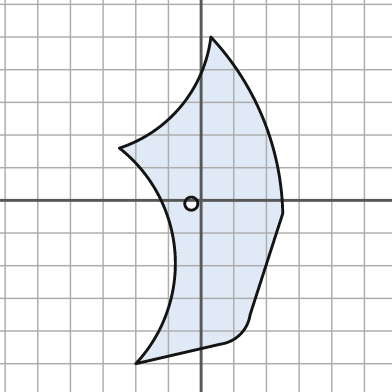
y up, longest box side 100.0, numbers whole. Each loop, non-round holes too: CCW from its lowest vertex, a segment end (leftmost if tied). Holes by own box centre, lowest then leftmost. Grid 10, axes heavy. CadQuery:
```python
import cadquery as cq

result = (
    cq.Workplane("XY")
    .moveTo(-20.0, -50.0)
    .lineTo(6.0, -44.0)
    .threePointArc((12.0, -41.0), (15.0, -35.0))
    .lineTo(25.0, -4.0)
    .threePointArc((19.0, 25.0), (3.0, 50.0))
    .threePointArc((-6.0, 29.0), (-25.0, 16.0))
    .threePointArc((-8.0, -16.0), (-20.0, -50.0))
    .close()
    .moveTo(-3.0, -1.0)
    .circle(2.0)
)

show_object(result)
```